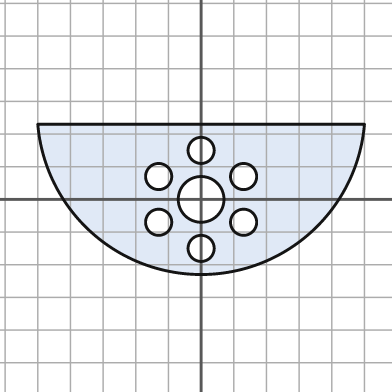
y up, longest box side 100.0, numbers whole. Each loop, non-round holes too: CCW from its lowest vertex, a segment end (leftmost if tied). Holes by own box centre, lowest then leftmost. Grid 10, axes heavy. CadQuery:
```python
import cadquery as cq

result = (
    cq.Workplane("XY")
    .moveTo(-50.0, 23.0)
    .threePointArc((0.0, -23.0), (50.0, 23.0))
    .close()
    .moveTo(0.0, -15.0)
    .circle(4.0)
    .moveTo(-13.0, -7.0)
    .circle(4.0)
    .moveTo(13.0, -7.0)
    .circle(4.0)
    .moveTo(0.0, 0.0)
    .circle(7.0)
    .moveTo(-13.0, 7.0)
    .circle(4.0)
    .moveTo(13.0, 7.0)
    .circle(4.0)
    .moveTo(0.0, 15.0)
    .circle(4.0)
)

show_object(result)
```